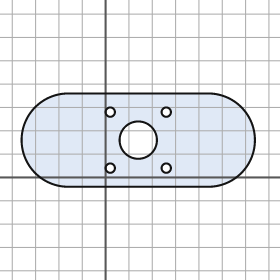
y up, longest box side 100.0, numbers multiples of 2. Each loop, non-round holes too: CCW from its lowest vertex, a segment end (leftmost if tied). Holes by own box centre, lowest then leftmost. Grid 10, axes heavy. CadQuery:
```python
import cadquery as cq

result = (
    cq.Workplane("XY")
    .moveTo(-16.0, -4.0)
    .lineTo(44.0, -4.0)
    .threePointArc((64.0, 16.0), (44.0, 36.0))
    .lineTo(-16.0, 36.0)
    .threePointArc((-36.0, 16.0), (-16.0, -4.0))
    .close()
    .moveTo(2.0, 4.0)
    .circle(2.0)
    .moveTo(26.0, 4.0)
    .circle(2.0)
    .moveTo(14.0, 16.0)
    .circle(8.0)
    .moveTo(2.0, 28.0)
    .circle(2.0)
    .moveTo(26.0, 28.0)
    .circle(2.0)
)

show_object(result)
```